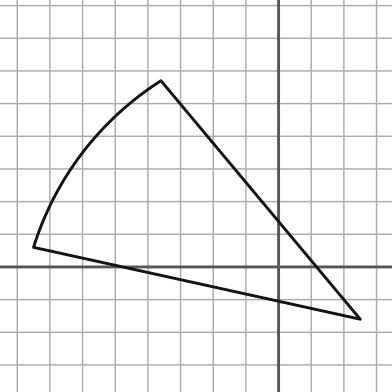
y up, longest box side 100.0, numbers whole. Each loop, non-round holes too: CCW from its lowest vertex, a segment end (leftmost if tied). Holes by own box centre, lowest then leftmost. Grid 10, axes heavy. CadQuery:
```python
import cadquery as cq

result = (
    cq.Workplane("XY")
    .moveTo(25.0, -16.0)
    .lineTo(-36.0, 57.0)
    .threePointArc((-60.0, 35.0), (-75.0, 6.0))
    .close()
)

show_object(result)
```